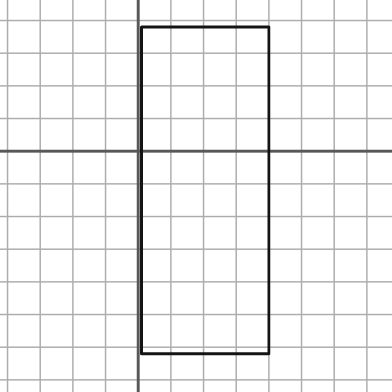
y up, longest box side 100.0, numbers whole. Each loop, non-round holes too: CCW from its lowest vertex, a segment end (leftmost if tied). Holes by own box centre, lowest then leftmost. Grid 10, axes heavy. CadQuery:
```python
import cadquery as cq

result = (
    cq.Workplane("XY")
    .moveTo(1.0, -62.0)
    .lineTo(40.0, -62.0)
    .lineTo(40.0, 38.0)
    .lineTo(1.0, 38.0)
    .close()
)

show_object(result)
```